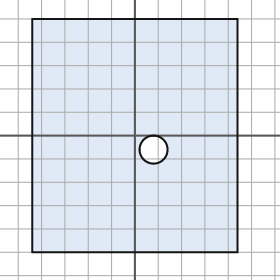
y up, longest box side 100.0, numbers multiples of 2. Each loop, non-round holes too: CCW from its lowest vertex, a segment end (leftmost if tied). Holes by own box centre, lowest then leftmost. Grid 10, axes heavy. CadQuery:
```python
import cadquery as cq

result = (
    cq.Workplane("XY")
    .moveTo(-44.0, -50.0)
    .lineTo(44.0, -50.0)
    .lineTo(44.0, 50.0)
    .lineTo(-44.0, 50.0)
    .close()
    .moveTo(8.0, -6.0)
    .circle(6.0)
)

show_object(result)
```